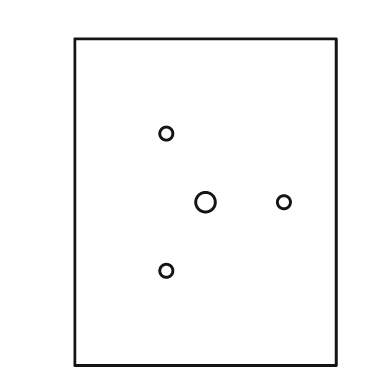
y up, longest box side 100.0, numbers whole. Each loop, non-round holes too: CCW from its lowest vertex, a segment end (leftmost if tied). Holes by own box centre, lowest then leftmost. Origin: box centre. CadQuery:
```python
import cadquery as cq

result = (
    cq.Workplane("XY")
    .moveTo(-40.0, -50.0)
    .lineTo(40.0, -50.0)
    .lineTo(40.0, 50.0)
    .lineTo(-40.0, 50.0)
    .close()
    .moveTo(-12.0, -21.0)
    .circle(2.0)
    .moveTo(0.0, 0.0)
    .circle(3.0)
    .moveTo(24.0, 0.0)
    .circle(2.0)
    .moveTo(-12.0, 21.0)
    .circle(2.0)
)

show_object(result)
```